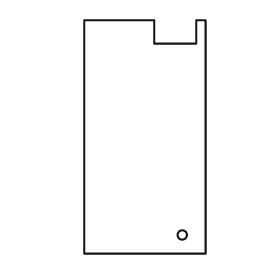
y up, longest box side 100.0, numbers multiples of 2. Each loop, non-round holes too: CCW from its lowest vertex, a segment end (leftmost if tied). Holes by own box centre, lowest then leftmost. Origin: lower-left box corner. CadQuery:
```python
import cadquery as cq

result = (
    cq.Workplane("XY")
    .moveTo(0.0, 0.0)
    .lineTo(52.0, 0.0)
    .lineTo(52.0, 100.0)
    .lineTo(48.0, 100.0)
    .lineTo(48.0, 90.0)
    .lineTo(30.0, 90.0)
    .lineTo(30.0, 100.0)
    .lineTo(0.0, 100.0)
    .close()
    .moveTo(42.0, 8.0)
    .circle(2.0)
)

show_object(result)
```